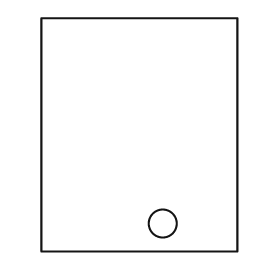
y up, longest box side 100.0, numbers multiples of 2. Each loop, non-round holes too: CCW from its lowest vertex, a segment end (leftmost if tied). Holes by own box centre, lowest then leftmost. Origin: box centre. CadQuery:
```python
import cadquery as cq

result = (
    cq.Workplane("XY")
    .moveTo(-42.0, -50.0)
    .lineTo(42.0, -50.0)
    .lineTo(42.0, 50.0)
    .lineTo(-42.0, 50.0)
    .close()
    .moveTo(10.0, -38.0)
    .circle(6.0)
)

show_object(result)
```